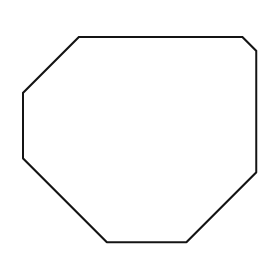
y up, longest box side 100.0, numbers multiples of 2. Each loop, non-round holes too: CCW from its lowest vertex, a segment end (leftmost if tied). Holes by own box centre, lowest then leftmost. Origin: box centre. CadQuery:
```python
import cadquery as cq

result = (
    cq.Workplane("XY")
    .moveTo(-14.0, -44.0)
    .lineTo(20.0, -44.0)
    .lineTo(50.0, -14.0)
    .lineTo(50.0, 38.0)
    .lineTo(44.0, 44.0)
    .lineTo(-26.0, 44.0)
    .lineTo(-50.0, 20.0)
    .lineTo(-50.0, -8.0)
    .close()
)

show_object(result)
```